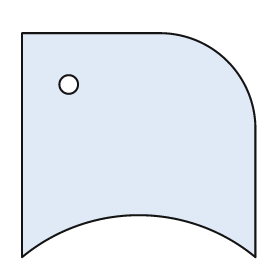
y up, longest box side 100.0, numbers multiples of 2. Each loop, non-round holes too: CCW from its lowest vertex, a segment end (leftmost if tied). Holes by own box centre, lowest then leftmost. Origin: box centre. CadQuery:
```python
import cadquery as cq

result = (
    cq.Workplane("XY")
    .moveTo(-50.0, -48.0)
    .threePointArc((0.0, -30.0), (50.0, -48.0))
    .lineTo(50.0, 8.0)
    .threePointArc((38.0, 36.0), (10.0, 48.0))
    .lineTo(-50.0, 48.0)
    .close()
    .moveTo(-30.0, 26.0)
    .circle(4.0)
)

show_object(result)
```